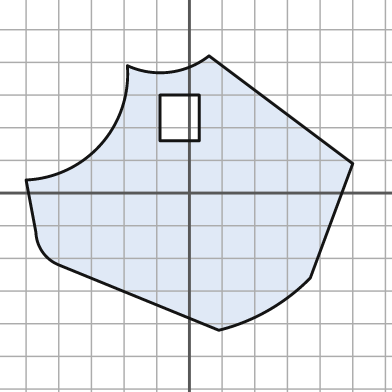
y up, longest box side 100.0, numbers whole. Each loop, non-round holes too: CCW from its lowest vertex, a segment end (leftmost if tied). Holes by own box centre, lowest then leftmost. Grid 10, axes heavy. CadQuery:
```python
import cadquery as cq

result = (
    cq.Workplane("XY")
    .moveTo(9.0, -42.0)
    .threePointArc((24.0, -36.0), (37.0, -26.0))
    .lineTo(50.0, 9.0)
    .lineTo(6.0, 42.0)
    .threePointArc((-6.0, 37.0), (-19.0, 39.0))
    .threePointArc((-27.0, 15.0), (-50.0, 4.0))
    .lineTo(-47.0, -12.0)
    .threePointArc((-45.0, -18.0), (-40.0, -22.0))
    .close()
    .moveTo(-9.0, 16.0)
    .lineTo(3.0, 16.0)
    .lineTo(3.0, 30.0)
    .lineTo(-9.0, 30.0)
    .close()
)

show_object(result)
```